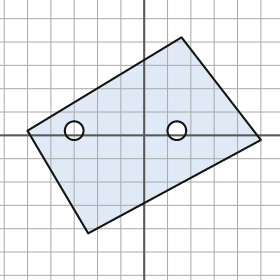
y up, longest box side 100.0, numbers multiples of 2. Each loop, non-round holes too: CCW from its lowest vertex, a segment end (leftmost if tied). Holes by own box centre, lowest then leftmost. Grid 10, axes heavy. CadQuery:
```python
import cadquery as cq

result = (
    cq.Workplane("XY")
    .moveTo(-24.0, -42.0)
    .lineTo(50.0, -2.0)
    .lineTo(16.0, 42.0)
    .lineTo(-50.0, 2.0)
    .close()
    .moveTo(-30.0, 2.0)
    .circle(4.0)
    .moveTo(14.0, 2.0)
    .circle(4.0)
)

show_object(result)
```